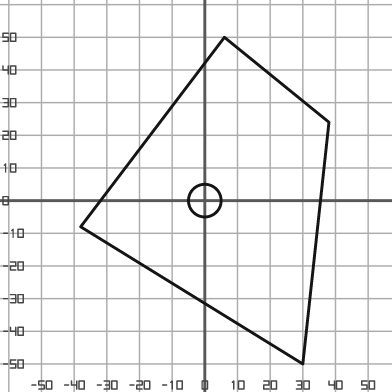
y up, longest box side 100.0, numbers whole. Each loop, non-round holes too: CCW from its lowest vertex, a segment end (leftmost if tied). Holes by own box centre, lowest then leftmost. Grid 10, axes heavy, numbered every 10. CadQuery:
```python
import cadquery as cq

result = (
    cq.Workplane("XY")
    .moveTo(30.0, -50.0)
    .lineTo(38.0, 24.0)
    .lineTo(6.0, 50.0)
    .lineTo(-38.0, -8.0)
    .close()
    .moveTo(0.0, 0.0)
    .circle(5.0)
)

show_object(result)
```